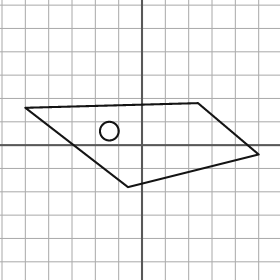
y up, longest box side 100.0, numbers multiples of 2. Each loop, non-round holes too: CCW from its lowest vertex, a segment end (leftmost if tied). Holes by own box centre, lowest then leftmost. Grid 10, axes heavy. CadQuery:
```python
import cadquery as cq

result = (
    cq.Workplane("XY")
    .moveTo(-6.0, -18.0)
    .lineTo(50.0, -4.0)
    .lineTo(24.0, 18.0)
    .lineTo(-50.0, 16.0)
    .close()
    .moveTo(-14.0, 6.0)
    .circle(4.0)
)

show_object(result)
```